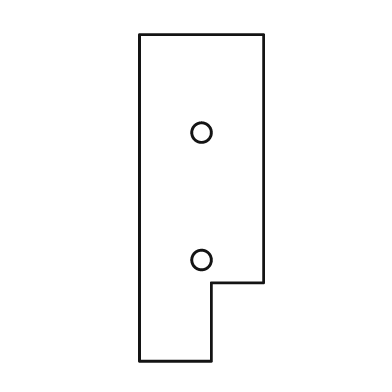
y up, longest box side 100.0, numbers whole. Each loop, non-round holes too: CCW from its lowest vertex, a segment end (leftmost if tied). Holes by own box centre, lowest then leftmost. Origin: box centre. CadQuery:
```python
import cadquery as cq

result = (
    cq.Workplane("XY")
    .moveTo(-19.0, -50.0)
    .lineTo(3.0, -50.0)
    .lineTo(3.0, -26.0)
    .lineTo(19.0, -26.0)
    .lineTo(19.0, 50.0)
    .lineTo(-19.0, 50.0)
    .close()
    .moveTo(0.0, -19.0)
    .circle(3.0)
    .moveTo(0.0, 20.0)
    .circle(3.0)
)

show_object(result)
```